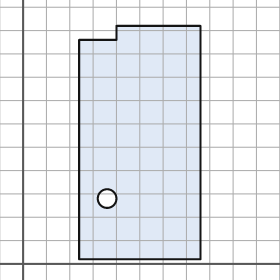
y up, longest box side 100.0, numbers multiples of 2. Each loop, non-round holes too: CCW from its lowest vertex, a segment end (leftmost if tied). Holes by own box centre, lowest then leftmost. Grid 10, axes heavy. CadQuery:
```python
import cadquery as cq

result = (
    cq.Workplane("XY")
    .moveTo(24.0, 2.0)
    .lineTo(76.0, 2.0)
    .lineTo(76.0, 102.0)
    .lineTo(40.0, 102.0)
    .lineTo(40.0, 96.0)
    .lineTo(24.0, 96.0)
    .close()
    .moveTo(36.0, 28.0)
    .circle(4.0)
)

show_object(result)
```